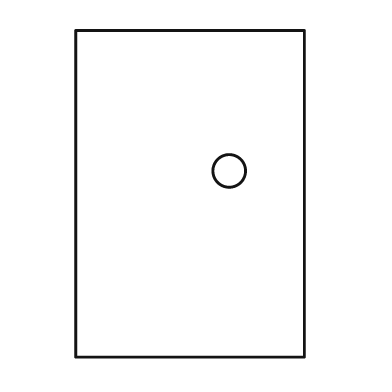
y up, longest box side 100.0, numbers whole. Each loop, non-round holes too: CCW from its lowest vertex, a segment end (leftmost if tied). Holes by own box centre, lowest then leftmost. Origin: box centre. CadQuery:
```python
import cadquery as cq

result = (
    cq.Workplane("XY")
    .moveTo(-35.0, -50.0)
    .lineTo(35.0, -50.0)
    .lineTo(35.0, 50.0)
    .lineTo(-35.0, 50.0)
    .close()
    .moveTo(12.0, 7.0)
    .circle(5.0)
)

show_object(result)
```